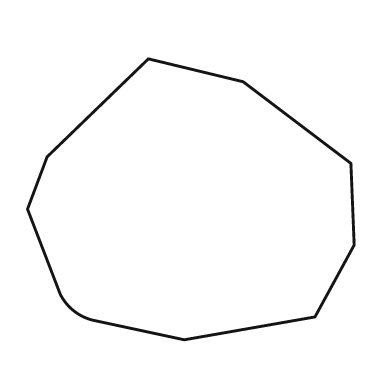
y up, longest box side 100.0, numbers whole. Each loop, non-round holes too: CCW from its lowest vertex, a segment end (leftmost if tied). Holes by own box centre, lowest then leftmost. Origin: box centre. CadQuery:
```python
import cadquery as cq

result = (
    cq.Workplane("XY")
    .moveTo(-2.0, -43.0)
    .lineTo(38.0, -36.0)
    .lineTo(50.0, -14.0)
    .lineTo(49.0, 11.0)
    .lineTo(16.0, 36.0)
    .lineTo(-13.0, 43.0)
    .lineTo(-44.0, 13.0)
    .lineTo(-50.0, -3.0)
    .lineTo(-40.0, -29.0)
    .threePointArc((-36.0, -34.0), (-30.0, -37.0))
    .close()
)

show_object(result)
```